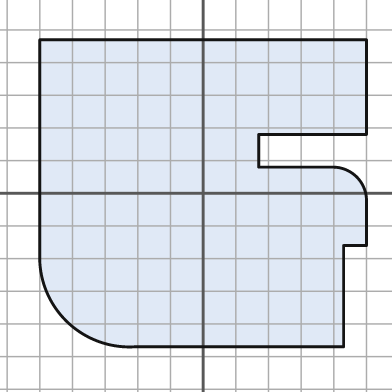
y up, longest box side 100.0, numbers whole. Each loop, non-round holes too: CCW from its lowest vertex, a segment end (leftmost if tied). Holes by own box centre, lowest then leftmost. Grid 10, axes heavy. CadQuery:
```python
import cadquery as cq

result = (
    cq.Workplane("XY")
    .moveTo(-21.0, -47.0)
    .lineTo(43.0, -47.0)
    .lineTo(43.0, -16.0)
    .lineTo(50.0, -16.0)
    .lineTo(50.0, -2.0)
    .threePointArc((47.0, 5.0), (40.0, 8.0))
    .lineTo(17.0, 8.0)
    .lineTo(17.0, 18.0)
    .lineTo(50.0, 18.0)
    .lineTo(50.0, 47.0)
    .lineTo(-50.0, 47.0)
    .lineTo(-50.0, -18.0)
    .threePointArc((-42.0, -39.0), (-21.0, -47.0))
    .close()
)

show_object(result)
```